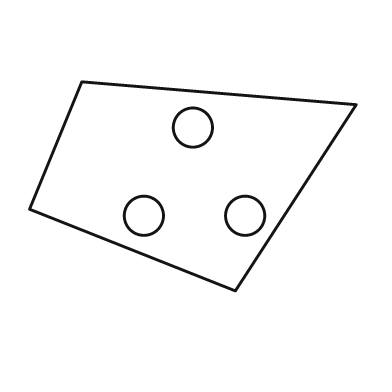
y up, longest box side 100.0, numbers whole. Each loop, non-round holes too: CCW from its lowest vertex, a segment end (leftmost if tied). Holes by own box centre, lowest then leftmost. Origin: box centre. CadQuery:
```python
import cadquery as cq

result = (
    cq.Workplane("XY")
    .moveTo(13.0, -32.0)
    .lineTo(50.0, 25.0)
    .lineTo(-34.0, 32.0)
    .lineTo(-50.0, -7.0)
    .close()
    .moveTo(-15.0, -9.0)
    .circle(6.0)
    .moveTo(16.0, -9.0)
    .circle(6.0)
    .moveTo(0.0, 18.0)
    .circle(6.0)
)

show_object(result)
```